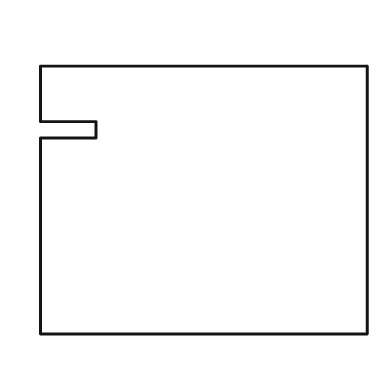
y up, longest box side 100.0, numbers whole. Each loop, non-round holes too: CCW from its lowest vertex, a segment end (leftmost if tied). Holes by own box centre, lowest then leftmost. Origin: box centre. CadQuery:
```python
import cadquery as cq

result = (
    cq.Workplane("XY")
    .moveTo(-50.0, -41.0)
    .lineTo(50.0, -41.0)
    .lineTo(50.0, 41.0)
    .lineTo(-50.0, 41.0)
    .lineTo(-50.0, 24.0)
    .lineTo(-33.0, 24.0)
    .lineTo(-33.0, 19.0)
    .lineTo(-50.0, 19.0)
    .close()
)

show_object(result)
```